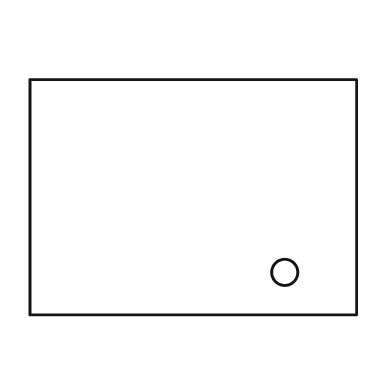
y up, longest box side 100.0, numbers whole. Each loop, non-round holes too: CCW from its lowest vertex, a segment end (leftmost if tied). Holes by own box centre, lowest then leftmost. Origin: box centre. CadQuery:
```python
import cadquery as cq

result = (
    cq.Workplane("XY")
    .moveTo(-50.0, -36.0)
    .lineTo(50.0, -36.0)
    .lineTo(50.0, 36.0)
    .lineTo(-50.0, 36.0)
    .close()
    .moveTo(28.0, -23.0)
    .circle(4.0)
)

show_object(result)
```